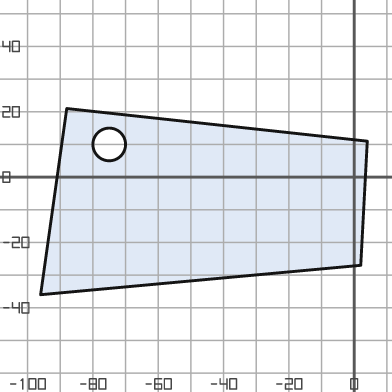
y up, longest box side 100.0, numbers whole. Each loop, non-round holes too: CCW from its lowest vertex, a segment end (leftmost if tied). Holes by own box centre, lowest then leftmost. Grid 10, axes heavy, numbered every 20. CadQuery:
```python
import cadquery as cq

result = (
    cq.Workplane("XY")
    .moveTo(-96.0, -36.0)
    .lineTo(2.0, -27.0)
    .lineTo(4.0, 11.0)
    .lineTo(-88.0, 21.0)
    .close()
    .moveTo(-75.0, 10.0)
    .circle(5.0)
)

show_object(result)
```